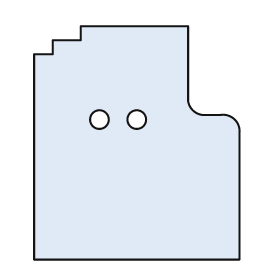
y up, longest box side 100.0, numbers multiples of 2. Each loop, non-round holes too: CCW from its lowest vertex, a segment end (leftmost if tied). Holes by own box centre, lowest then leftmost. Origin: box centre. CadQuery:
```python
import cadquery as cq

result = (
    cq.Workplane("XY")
    .moveTo(-44.0, -50.0)
    .lineTo(44.0, -50.0)
    .lineTo(44.0, 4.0)
    .threePointArc((42.0, 10.0), (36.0, 12.0))
    .lineTo(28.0, 12.0)
    .threePointArc((24.0, 14.0), (22.0, 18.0))
    .lineTo(22.0, 50.0)
    .lineTo(-24.0, 50.0)
    .lineTo(-24.0, 44.0)
    .lineTo(-36.0, 44.0)
    .lineTo(-36.0, 38.0)
    .lineTo(-44.0, 38.0)
    .close()
    .moveTo(-16.0, 10.0)
    .circle(4.0)
    .moveTo(0.0, 10.0)
    .circle(4.0)
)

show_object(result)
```